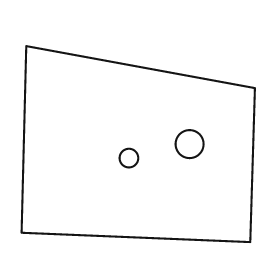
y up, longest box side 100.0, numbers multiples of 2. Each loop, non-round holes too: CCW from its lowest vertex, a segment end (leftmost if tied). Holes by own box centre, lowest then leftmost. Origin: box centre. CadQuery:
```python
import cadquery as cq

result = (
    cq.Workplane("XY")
    .moveTo(48.0, -42.0)
    .lineTo(50.0, 24.0)
    .lineTo(-48.0, 42.0)
    .lineTo(-50.0, -38.0)
    .close()
    .moveTo(-4.0, -6.0)
    .circle(4.0)
    .moveTo(22.0, 0.0)
    .circle(6.0)
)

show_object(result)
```